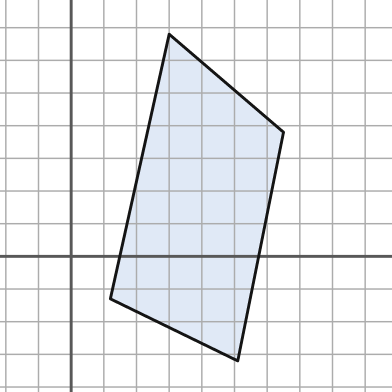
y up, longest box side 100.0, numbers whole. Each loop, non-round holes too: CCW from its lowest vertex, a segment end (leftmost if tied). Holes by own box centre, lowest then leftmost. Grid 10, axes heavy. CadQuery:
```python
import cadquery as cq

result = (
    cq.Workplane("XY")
    .moveTo(51.0, -32.0)
    .lineTo(65.0, 38.0)
    .lineTo(30.0, 68.0)
    .lineTo(12.0, -13.0)
    .close()
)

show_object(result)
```